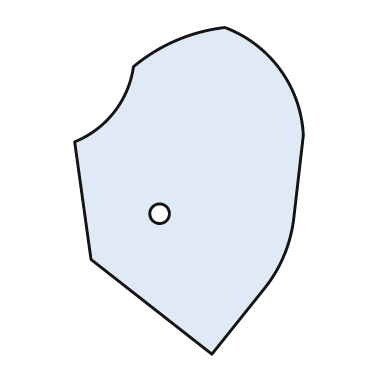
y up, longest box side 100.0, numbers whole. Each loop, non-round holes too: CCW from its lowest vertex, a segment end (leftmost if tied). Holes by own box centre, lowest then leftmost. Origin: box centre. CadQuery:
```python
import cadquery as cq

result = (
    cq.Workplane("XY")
    .moveTo(7.0, -50.0)
    .lineTo(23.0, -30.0)
    .threePointArc((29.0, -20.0), (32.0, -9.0))
    .lineTo(35.0, 17.0)
    .threePointArc((28.0, 37.0), (11.0, 50.0))
    .threePointArc((-4.0, 46.0), (-17.0, 38.0))
    .threePointArc((-23.0, 24.0), (-35.0, 15.0))
    .lineTo(-30.0, -21.0)
    .close()
    .moveTo(-9.0, -7.0)
    .circle(3.0)
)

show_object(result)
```